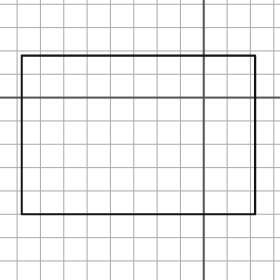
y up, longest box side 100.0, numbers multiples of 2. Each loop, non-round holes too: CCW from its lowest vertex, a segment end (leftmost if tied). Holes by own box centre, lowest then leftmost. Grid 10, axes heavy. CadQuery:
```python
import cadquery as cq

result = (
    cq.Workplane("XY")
    .moveTo(-78.0, -50.0)
    .lineTo(22.0, -50.0)
    .lineTo(22.0, 18.0)
    .lineTo(-78.0, 18.0)
    .close()
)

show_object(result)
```